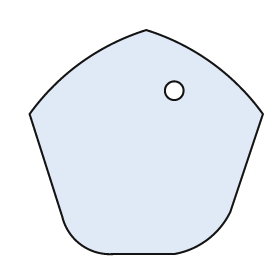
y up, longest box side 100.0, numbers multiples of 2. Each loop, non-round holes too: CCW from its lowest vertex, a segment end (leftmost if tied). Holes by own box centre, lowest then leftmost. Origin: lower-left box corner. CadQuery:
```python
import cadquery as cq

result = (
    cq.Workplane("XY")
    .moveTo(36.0, 0.0)
    .lineTo(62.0, 0.0)
    .threePointArc((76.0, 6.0), (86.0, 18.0))
    .lineTo(100.0, 60.0)
    .threePointArc((78.0, 82.0), (50.0, 96.0))
    .threePointArc((22.0, 82.0), (0.0, 60.0))
    .lineTo(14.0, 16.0)
    .threePointArc((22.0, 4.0), (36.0, 0.0))
    .close()
    .moveTo(62.0, 70.0)
    .circle(4.0)
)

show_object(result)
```